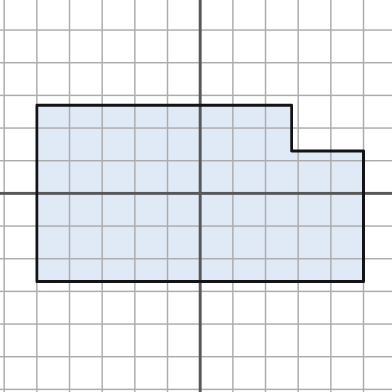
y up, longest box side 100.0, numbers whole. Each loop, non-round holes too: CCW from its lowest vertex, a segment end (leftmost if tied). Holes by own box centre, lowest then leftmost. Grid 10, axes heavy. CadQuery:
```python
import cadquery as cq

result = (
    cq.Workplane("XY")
    .moveTo(-50.0, -27.0)
    .lineTo(50.0, -27.0)
    .lineTo(50.0, 13.0)
    .lineTo(28.0, 13.0)
    .lineTo(28.0, 27.0)
    .lineTo(-50.0, 27.0)
    .close()
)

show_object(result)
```